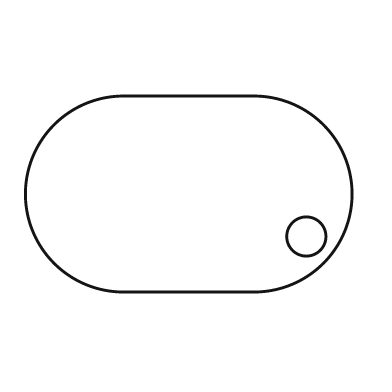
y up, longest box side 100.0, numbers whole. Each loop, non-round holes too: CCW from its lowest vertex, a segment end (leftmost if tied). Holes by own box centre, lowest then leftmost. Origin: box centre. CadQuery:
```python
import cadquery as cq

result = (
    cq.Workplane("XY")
    .moveTo(-20.0, -30.0)
    .lineTo(20.0, -30.0)
    .threePointArc((50.0, 0.0), (20.0, 30.0))
    .lineTo(-20.0, 30.0)
    .threePointArc((-50.0, 0.0), (-20.0, -30.0))
    .close()
    .moveTo(36.0, -13.0)
    .circle(6.0)
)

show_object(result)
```